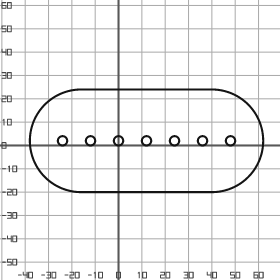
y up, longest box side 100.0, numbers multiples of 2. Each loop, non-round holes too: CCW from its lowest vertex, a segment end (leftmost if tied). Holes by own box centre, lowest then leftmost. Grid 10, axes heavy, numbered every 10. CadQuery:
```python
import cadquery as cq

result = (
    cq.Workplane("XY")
    .moveTo(-16.0, -20.0)
    .lineTo(40.0, -20.0)
    .threePointArc((62.0, 2.0), (40.0, 24.0))
    .lineTo(-16.0, 24.0)
    .threePointArc((-38.0, 2.0), (-16.0, -20.0))
    .close()
    .moveTo(-24.0, 2.0)
    .circle(2.0)
    .moveTo(-12.0, 2.0)
    .circle(2.0)
    .moveTo(0.0, 2.0)
    .circle(2.0)
    .moveTo(12.0, 2.0)
    .circle(2.0)
    .moveTo(24.0, 2.0)
    .circle(2.0)
    .moveTo(36.0, 2.0)
    .circle(2.0)
    .moveTo(48.0, 2.0)
    .circle(2.0)
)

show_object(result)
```